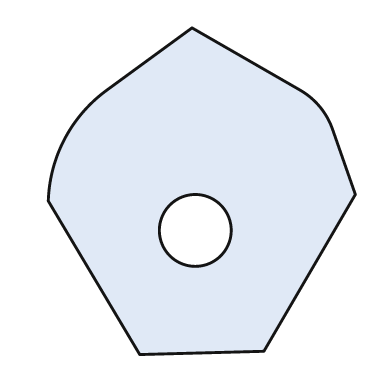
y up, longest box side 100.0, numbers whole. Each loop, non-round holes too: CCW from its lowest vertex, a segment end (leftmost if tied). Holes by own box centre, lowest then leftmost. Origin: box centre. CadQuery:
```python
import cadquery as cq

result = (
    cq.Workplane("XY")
    .moveTo(-19.0, -50.0)
    .lineTo(19.0, -49.0)
    .lineTo(47.0, -1.0)
    .lineTo(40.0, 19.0)
    .threePointArc((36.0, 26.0), (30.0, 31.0))
    .lineTo(-3.0, 50.0)
    .lineTo(-29.0, 31.0)
    .threePointArc((-42.0, 16.0), (-47.0, -3.0))
    .close()
    .moveTo(-2.0, -12.0)
    .circle(11.0)
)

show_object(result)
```